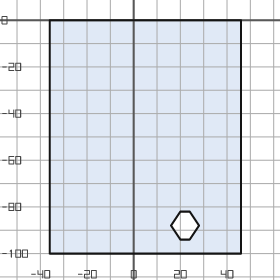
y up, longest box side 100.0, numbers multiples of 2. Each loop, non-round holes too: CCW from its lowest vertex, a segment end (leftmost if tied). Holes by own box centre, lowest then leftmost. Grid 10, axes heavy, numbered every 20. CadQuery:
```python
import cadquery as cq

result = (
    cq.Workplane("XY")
    .moveTo(-36.0, -100.0)
    .lineTo(46.0, -100.0)
    .lineTo(46.0, 0.0)
    .lineTo(-36.0, 0.0)
    .close()
    .moveTo(20.0, -94.0)
    .lineTo(24.0, -94.0)
    .lineTo(28.0, -88.0)
    .lineTo(24.0, -82.0)
    .lineTo(20.0, -82.0)
    .lineTo(16.0, -88.0)
    .close()
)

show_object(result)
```